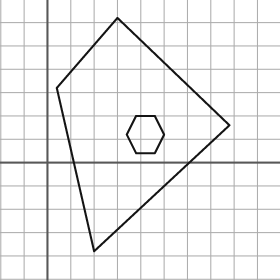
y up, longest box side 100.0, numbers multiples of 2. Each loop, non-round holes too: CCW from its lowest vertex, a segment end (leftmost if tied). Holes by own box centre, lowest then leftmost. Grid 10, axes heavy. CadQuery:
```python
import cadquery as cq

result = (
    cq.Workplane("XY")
    .moveTo(20.0, -38.0)
    .lineTo(78.0, 16.0)
    .lineTo(30.0, 62.0)
    .lineTo(4.0, 32.0)
    .close()
    .moveTo(38.0, 4.0)
    .lineTo(46.0, 4.0)
    .lineTo(50.0, 12.0)
    .lineTo(46.0, 20.0)
    .lineTo(38.0, 20.0)
    .lineTo(34.0, 12.0)
    .close()
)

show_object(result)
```